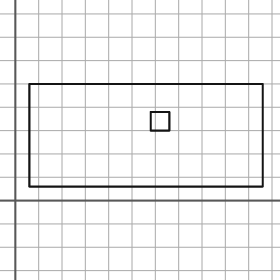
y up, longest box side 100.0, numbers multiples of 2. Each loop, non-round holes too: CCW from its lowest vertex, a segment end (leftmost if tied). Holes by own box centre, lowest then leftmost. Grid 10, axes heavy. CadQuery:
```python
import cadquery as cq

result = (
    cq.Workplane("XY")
    .moveTo(6.0, 6.0)
    .lineTo(106.0, 6.0)
    .lineTo(106.0, 50.0)
    .lineTo(6.0, 50.0)
    .close()
    .moveTo(58.0, 30.0)
    .lineTo(66.0, 30.0)
    .lineTo(66.0, 38.0)
    .lineTo(58.0, 38.0)
    .close()
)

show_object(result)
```